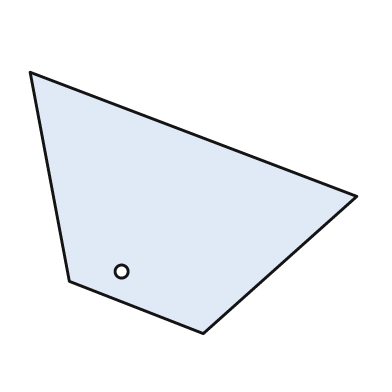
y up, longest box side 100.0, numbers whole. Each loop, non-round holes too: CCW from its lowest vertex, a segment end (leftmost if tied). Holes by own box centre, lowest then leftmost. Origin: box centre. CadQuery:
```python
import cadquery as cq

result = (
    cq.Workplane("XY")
    .moveTo(3.0, -40.0)
    .lineTo(50.0, 2.0)
    .lineTo(-50.0, 40.0)
    .lineTo(-38.0, -24.0)
    .close()
    .moveTo(-22.0, -21.0)
    .circle(2.0)
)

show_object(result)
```